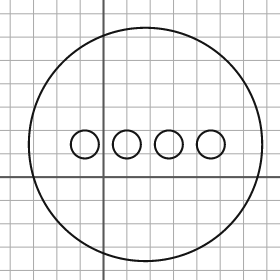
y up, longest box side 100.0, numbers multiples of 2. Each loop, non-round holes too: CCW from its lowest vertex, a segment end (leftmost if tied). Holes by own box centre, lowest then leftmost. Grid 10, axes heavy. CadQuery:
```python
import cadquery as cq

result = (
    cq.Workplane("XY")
    .moveTo(18.0, 14.0)
    .circle(50.0)
    .moveTo(-8.0, 14.0)
    .circle(6.0)
    .moveTo(10.0, 14.0)
    .circle(6.0)
    .moveTo(28.0, 14.0)
    .circle(6.0)
    .moveTo(46.0, 14.0)
    .circle(6.0)
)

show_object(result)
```